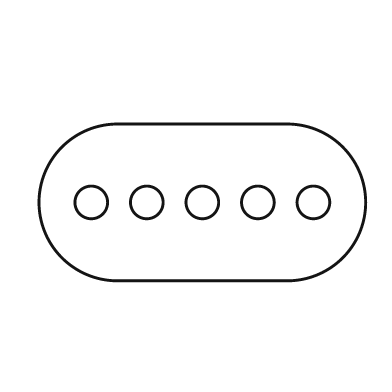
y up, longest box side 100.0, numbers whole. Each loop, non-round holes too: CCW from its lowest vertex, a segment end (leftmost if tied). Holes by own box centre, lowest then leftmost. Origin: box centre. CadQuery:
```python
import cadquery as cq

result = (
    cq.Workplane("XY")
    .moveTo(-26.0, -24.0)
    .lineTo(26.0, -24.0)
    .threePointArc((50.0, 0.0), (26.0, 24.0))
    .lineTo(-26.0, 24.0)
    .threePointArc((-50.0, 0.0), (-26.0, -24.0))
    .close()
    .moveTo(-34.0, 0.0)
    .circle(5.0)
    .moveTo(-17.0, 0.0)
    .circle(5.0)
    .moveTo(0.0, 0.0)
    .circle(5.0)
    .moveTo(17.0, 0.0)
    .circle(5.0)
    .moveTo(34.0, 0.0)
    .circle(5.0)
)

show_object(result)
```